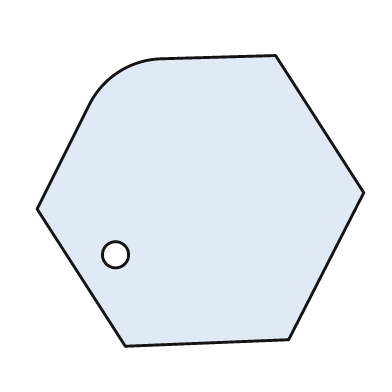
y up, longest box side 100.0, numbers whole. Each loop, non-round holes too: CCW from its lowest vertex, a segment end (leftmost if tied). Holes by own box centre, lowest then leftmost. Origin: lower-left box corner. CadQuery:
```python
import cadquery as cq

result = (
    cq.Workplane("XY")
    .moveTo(27.0, 0.0)
    .lineTo(77.0, 2.0)
    .lineTo(100.0, 47.0)
    .lineTo(73.0, 89.0)
    .lineTo(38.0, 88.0)
    .threePointArc((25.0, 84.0), (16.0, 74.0))
    .lineTo(0.0, 42.0)
    .close()
    .moveTo(24.0, 28.0)
    .circle(4.0)
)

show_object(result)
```